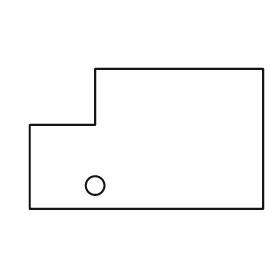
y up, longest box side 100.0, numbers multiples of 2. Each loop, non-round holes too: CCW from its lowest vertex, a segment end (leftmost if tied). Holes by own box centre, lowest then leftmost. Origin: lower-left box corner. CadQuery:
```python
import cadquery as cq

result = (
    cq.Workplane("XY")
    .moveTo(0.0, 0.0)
    .lineTo(100.0, 0.0)
    .lineTo(100.0, 60.0)
    .lineTo(28.0, 60.0)
    .lineTo(28.0, 36.0)
    .lineTo(0.0, 36.0)
    .close()
    .moveTo(28.0, 10.0)
    .circle(4.0)
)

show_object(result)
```